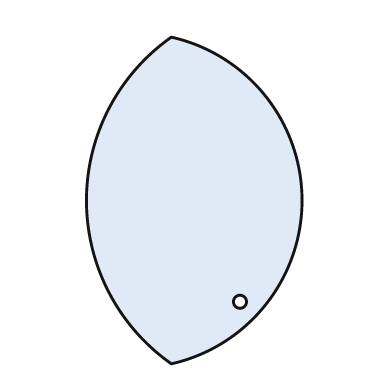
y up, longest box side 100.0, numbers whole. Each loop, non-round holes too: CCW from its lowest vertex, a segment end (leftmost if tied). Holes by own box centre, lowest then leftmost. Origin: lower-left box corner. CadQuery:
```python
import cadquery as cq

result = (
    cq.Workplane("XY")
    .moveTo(26.0, 0.0)
    .threePointArc((66.0, 50.0), (26.0, 100.0))
    .threePointArc((0.0, 50.0), (26.0, 0.0))
    .close()
    .moveTo(47.0, 19.0)
    .circle(2.0)
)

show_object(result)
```